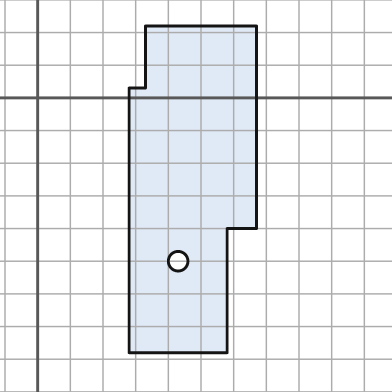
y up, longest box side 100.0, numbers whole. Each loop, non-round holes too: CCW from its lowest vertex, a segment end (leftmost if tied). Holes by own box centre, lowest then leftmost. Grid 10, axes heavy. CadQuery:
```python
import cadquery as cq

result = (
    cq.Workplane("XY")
    .moveTo(28.0, -78.0)
    .lineTo(58.0, -78.0)
    .lineTo(58.0, -40.0)
    .lineTo(67.0, -40.0)
    .lineTo(67.0, 22.0)
    .lineTo(33.0, 22.0)
    .lineTo(33.0, 3.0)
    .lineTo(28.0, 3.0)
    .close()
    .moveTo(43.0, -50.0)
    .circle(3.0)
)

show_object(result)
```